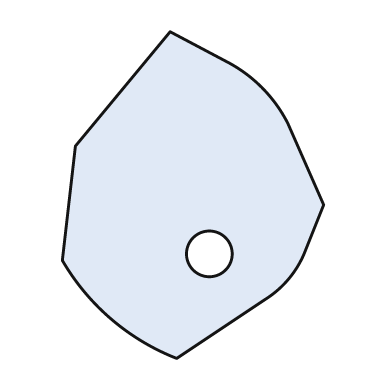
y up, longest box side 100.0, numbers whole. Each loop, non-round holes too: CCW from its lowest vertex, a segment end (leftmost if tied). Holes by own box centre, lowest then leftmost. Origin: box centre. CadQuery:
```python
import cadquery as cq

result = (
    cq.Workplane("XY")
    .moveTo(-5.0, -50.0)
    .lineTo(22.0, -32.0)
    .threePointArc((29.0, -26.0), (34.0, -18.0))
    .lineTo(40.0, -3.0)
    .lineTo(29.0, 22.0)
    .threePointArc((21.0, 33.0), (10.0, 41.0))
    .lineTo(-7.0, 50.0)
    .lineTo(-36.0, 15.0)
    .lineTo(-40.0, -20.0)
    .threePointArc((-25.0, -38.0), (-5.0, -50.0))
    .close()
    .moveTo(5.0, -18.0)
    .circle(7.0)
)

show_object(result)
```